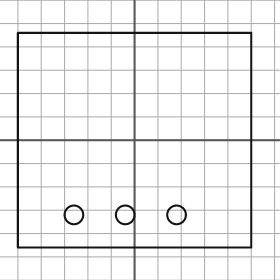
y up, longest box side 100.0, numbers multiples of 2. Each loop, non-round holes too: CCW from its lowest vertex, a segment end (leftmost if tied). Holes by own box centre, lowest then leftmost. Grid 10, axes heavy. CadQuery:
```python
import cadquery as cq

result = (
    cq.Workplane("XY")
    .moveTo(-50.0, -46.0)
    .lineTo(50.0, -46.0)
    .lineTo(50.0, 46.0)
    .lineTo(-50.0, 46.0)
    .close()
    .moveTo(-26.0, -32.0)
    .circle(4.0)
    .moveTo(-4.0, -32.0)
    .circle(4.0)
    .moveTo(18.0, -32.0)
    .circle(4.0)
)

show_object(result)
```